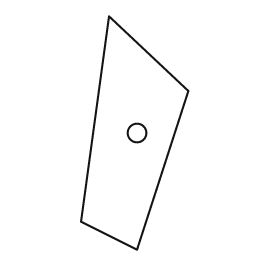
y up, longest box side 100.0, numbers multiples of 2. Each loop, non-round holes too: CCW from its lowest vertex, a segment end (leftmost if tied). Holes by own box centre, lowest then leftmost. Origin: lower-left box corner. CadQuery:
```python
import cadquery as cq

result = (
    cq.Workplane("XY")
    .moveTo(24.0, 0.0)
    .lineTo(46.0, 68.0)
    .lineTo(12.0, 100.0)
    .lineTo(0.0, 12.0)
    .close()
    .moveTo(24.0, 50.0)
    .circle(4.0)
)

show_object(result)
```